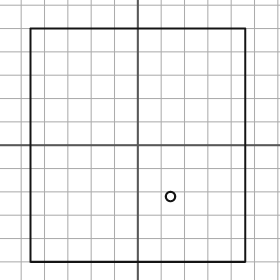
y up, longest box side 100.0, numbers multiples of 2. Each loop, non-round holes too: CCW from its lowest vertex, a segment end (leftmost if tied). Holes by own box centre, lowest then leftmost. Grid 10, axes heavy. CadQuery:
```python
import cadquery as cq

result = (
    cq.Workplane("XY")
    .moveTo(-46.0, -50.0)
    .lineTo(46.0, -50.0)
    .lineTo(46.0, 50.0)
    .lineTo(-46.0, 50.0)
    .close()
    .moveTo(14.0, -22.0)
    .circle(2.0)
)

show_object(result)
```